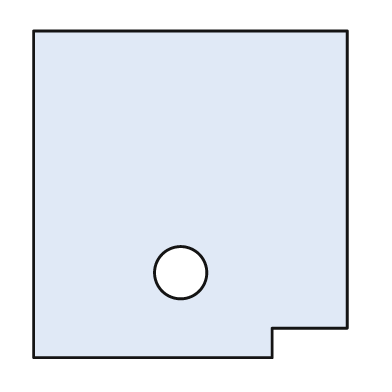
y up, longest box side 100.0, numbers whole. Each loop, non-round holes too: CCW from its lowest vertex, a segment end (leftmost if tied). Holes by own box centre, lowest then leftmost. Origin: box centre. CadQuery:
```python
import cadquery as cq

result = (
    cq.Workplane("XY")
    .moveTo(-48.0, -50.0)
    .lineTo(25.0, -50.0)
    .lineTo(25.0, -41.0)
    .lineTo(48.0, -41.0)
    .lineTo(48.0, 50.0)
    .lineTo(-48.0, 50.0)
    .close()
    .moveTo(-3.0, -24.0)
    .circle(8.0)
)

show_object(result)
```